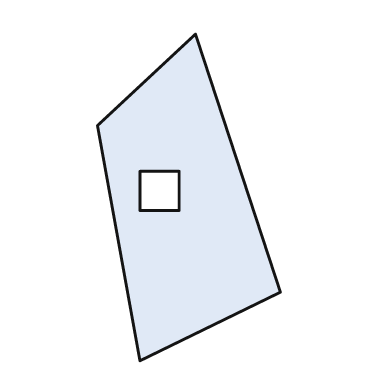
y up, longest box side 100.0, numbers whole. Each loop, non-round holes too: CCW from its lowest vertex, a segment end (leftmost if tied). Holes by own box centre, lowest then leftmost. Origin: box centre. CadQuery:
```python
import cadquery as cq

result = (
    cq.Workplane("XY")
    .moveTo(-15.0, -50.0)
    .lineTo(28.0, -29.0)
    .lineTo(2.0, 50.0)
    .lineTo(-28.0, 22.0)
    .close()
    .moveTo(-15.0, -4.0)
    .lineTo(-3.0, -4.0)
    .lineTo(-3.0, 8.0)
    .lineTo(-15.0, 8.0)
    .close()
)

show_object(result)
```